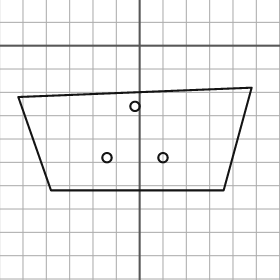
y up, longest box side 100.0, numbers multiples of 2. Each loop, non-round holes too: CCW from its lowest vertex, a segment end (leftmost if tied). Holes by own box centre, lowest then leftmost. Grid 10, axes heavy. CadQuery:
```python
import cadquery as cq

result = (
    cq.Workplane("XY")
    .moveTo(-38.0, -62.0)
    .lineTo(36.0, -62.0)
    .lineTo(48.0, -18.0)
    .lineTo(-52.0, -22.0)
    .close()
    .moveTo(-14.0, -48.0)
    .circle(2.0)
    .moveTo(10.0, -48.0)
    .circle(2.0)
    .moveTo(-2.0, -26.0)
    .circle(2.0)
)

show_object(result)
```